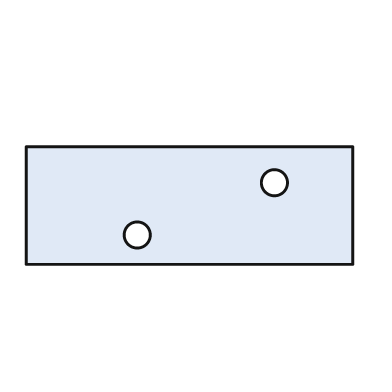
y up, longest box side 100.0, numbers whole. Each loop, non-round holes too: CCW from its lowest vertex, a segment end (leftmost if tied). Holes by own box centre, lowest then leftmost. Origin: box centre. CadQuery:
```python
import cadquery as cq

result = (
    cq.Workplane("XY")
    .moveTo(-50.0, -18.0)
    .lineTo(50.0, -18.0)
    .lineTo(50.0, 18.0)
    .lineTo(-50.0, 18.0)
    .close()
    .moveTo(-16.0, -9.0)
    .circle(4.0)
    .moveTo(26.0, 7.0)
    .circle(4.0)
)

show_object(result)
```